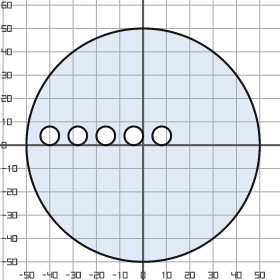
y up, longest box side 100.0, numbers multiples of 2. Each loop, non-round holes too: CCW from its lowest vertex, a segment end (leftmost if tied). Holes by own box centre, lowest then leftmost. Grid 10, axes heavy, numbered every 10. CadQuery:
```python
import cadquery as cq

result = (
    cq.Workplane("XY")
    .moveTo(0.0, 0.0)
    .circle(50.0)
    .moveTo(-40.0, 4.0)
    .circle(4.0)
    .moveTo(-28.0, 4.0)
    .circle(4.0)
    .moveTo(-16.0, 4.0)
    .circle(4.0)
    .moveTo(-4.0, 4.0)
    .circle(4.0)
    .moveTo(8.0, 4.0)
    .circle(4.0)
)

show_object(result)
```